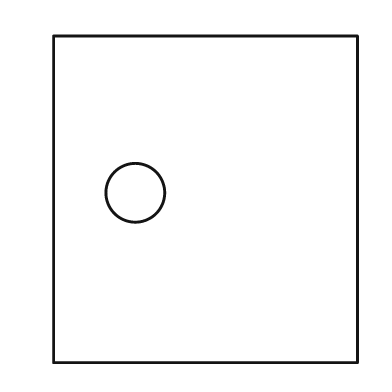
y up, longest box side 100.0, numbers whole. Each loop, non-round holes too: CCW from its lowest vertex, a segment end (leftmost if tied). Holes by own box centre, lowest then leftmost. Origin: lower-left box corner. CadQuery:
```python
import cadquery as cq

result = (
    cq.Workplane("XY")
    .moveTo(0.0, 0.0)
    .lineTo(93.0, 0.0)
    .lineTo(93.0, 100.0)
    .lineTo(0.0, 100.0)
    .close()
    .moveTo(25.0, 52.0)
    .circle(9.0)
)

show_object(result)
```